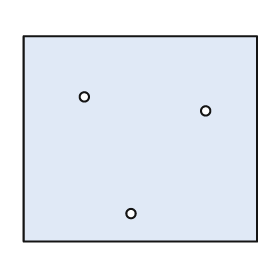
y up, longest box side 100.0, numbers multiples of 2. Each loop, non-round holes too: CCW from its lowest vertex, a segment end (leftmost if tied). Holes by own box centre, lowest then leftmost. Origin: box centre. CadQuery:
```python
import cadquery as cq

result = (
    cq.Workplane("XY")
    .moveTo(-50.0, -44.0)
    .lineTo(50.0, -44.0)
    .lineTo(50.0, 44.0)
    .lineTo(-50.0, 44.0)
    .close()
    .moveTo(-4.0, -32.0)
    .circle(2.0)
    .moveTo(28.0, 12.0)
    .circle(2.0)
    .moveTo(-24.0, 18.0)
    .circle(2.0)
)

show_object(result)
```